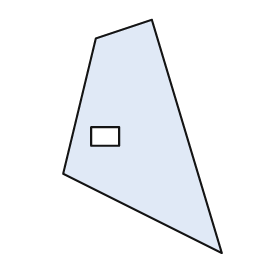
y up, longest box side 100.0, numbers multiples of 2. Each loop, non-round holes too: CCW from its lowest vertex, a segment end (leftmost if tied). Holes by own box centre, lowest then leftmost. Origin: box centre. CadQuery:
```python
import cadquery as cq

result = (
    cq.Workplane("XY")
    .moveTo(34.0, -50.0)
    .lineTo(4.0, 50.0)
    .lineTo(-20.0, 42.0)
    .lineTo(-34.0, -16.0)
    .close()
    .moveTo(-22.0, -4.0)
    .lineTo(-10.0, -4.0)
    .lineTo(-10.0, 4.0)
    .lineTo(-22.0, 4.0)
    .close()
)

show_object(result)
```